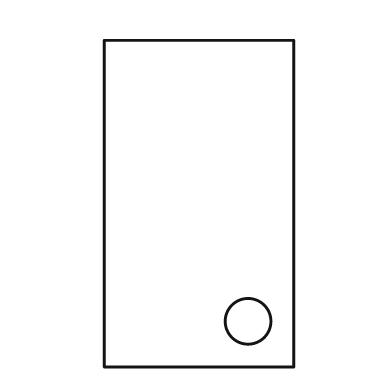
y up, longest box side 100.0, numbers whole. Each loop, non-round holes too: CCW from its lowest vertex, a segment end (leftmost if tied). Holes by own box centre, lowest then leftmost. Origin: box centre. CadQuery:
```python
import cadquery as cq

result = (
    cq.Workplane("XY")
    .moveTo(-29.0, -50.0)
    .lineTo(29.0, -50.0)
    .lineTo(29.0, 50.0)
    .lineTo(-29.0, 50.0)
    .close()
    .moveTo(15.0, -36.0)
    .circle(7.0)
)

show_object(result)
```